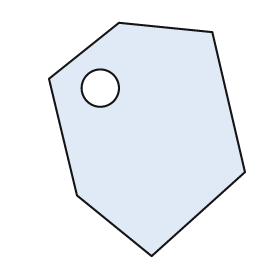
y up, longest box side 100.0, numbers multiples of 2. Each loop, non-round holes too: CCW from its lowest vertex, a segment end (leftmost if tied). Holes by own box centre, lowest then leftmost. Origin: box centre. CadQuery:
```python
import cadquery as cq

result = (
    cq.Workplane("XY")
    .moveTo(2.0, -50.0)
    .lineTo(42.0, -14.0)
    .lineTo(28.0, 46.0)
    .lineTo(-12.0, 50.0)
    .lineTo(-42.0, 26.0)
    .lineTo(-30.0, -24.0)
    .close()
    .moveTo(-20.0, 22.0)
    .circle(8.0)
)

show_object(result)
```